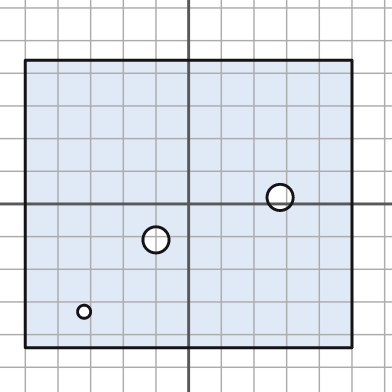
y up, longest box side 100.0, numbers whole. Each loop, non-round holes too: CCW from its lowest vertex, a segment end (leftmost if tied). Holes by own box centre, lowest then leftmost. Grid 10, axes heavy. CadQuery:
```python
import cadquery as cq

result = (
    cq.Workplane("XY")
    .moveTo(-50.0, -44.0)
    .lineTo(50.0, -44.0)
    .lineTo(50.0, 44.0)
    .lineTo(-50.0, 44.0)
    .close()
    .moveTo(-32.0, -33.0)
    .circle(2.0)
    .moveTo(-10.0, -11.0)
    .circle(4.0)
    .moveTo(28.0, 2.0)
    .circle(4.0)
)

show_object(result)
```